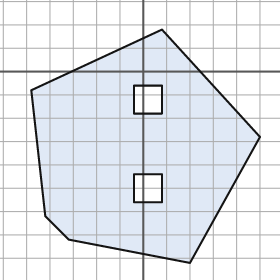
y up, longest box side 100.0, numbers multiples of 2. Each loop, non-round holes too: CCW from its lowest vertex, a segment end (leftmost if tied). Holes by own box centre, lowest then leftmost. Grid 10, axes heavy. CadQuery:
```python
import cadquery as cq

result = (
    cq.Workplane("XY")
    .moveTo(20.0, -82.0)
    .lineTo(50.0, -28.0)
    .lineTo(8.0, 18.0)
    .lineTo(-48.0, -8.0)
    .lineTo(-42.0, -62.0)
    .lineTo(-32.0, -72.0)
    .close()
    .moveTo(-4.0, -56.0)
    .lineTo(8.0, -56.0)
    .lineTo(8.0, -44.0)
    .lineTo(-4.0, -44.0)
    .close()
    .moveTo(-4.0, -18.0)
    .lineTo(8.0, -18.0)
    .lineTo(8.0, -6.0)
    .lineTo(-4.0, -6.0)
    .close()
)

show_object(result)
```